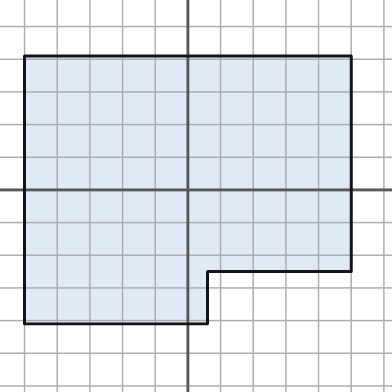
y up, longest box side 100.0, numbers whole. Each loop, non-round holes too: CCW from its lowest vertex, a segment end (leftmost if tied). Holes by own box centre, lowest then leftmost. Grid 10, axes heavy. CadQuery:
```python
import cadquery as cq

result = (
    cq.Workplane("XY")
    .moveTo(-50.0, -41.0)
    .lineTo(6.0, -41.0)
    .lineTo(6.0, -25.0)
    .lineTo(50.0, -25.0)
    .lineTo(50.0, 41.0)
    .lineTo(-50.0, 41.0)
    .close()
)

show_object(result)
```